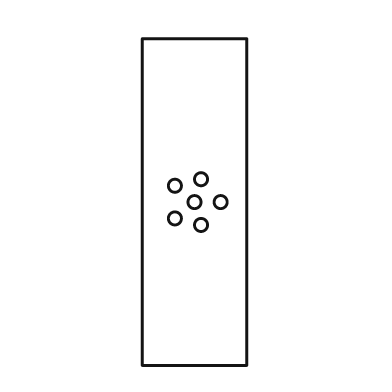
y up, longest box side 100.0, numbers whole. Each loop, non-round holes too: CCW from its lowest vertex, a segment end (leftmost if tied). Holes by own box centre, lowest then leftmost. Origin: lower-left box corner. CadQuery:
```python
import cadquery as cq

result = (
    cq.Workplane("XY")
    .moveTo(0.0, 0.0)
    .lineTo(32.0, 0.0)
    .lineTo(32.0, 100.0)
    .lineTo(0.0, 100.0)
    .close()
    .moveTo(18.0, 43.0)
    .circle(2.0)
    .moveTo(10.0, 45.0)
    .circle(2.0)
    .moveTo(16.0, 50.0)
    .circle(2.0)
    .moveTo(24.0, 50.0)
    .circle(2.0)
    .moveTo(10.0, 55.0)
    .circle(2.0)
    .moveTo(18.0, 57.0)
    .circle(2.0)
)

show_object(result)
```